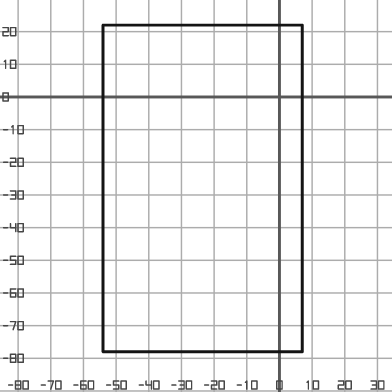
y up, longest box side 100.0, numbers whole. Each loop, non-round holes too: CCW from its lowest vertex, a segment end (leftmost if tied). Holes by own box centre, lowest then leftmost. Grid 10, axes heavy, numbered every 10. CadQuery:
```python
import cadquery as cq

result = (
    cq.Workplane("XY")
    .moveTo(-54.0, -78.0)
    .lineTo(7.0, -78.0)
    .lineTo(7.0, 22.0)
    .lineTo(-54.0, 22.0)
    .close()
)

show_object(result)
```